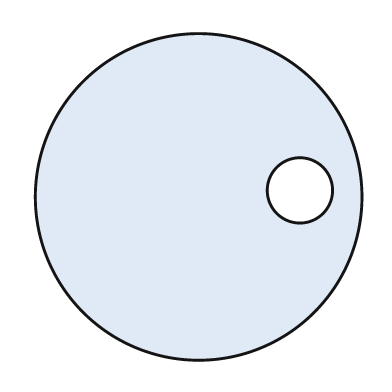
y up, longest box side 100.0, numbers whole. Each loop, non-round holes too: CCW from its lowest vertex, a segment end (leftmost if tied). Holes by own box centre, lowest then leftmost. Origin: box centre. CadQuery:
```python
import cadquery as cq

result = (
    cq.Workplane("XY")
    .moveTo(0.0, 0.0)
    .circle(50.0)
    .moveTo(31.0, 2.0)
    .circle(10.0)
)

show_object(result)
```